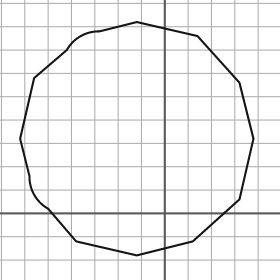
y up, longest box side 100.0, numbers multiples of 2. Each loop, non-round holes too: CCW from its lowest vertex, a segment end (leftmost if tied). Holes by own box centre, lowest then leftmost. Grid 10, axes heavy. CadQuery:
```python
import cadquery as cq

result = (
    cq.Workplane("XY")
    .moveTo(-12.0, -18.0)
    .lineTo(12.0, -12.0)
    .lineTo(32.0, 6.0)
    .lineTo(38.0, 32.0)
    .lineTo(32.0, 56.0)
    .lineTo(14.0, 76.0)
    .lineTo(-12.0, 82.0)
    .lineTo(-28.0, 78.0)
    .threePointArc((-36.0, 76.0), (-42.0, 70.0))
    .lineTo(-56.0, 58.0)
    .lineTo(-62.0, 32.0)
    .lineTo(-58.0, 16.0)
    .threePointArc((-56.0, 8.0), (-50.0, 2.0))
    .lineTo(-38.0, -12.0)
    .close()
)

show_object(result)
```